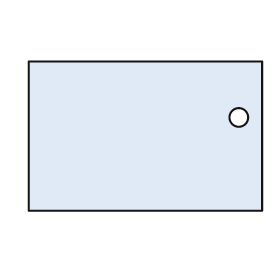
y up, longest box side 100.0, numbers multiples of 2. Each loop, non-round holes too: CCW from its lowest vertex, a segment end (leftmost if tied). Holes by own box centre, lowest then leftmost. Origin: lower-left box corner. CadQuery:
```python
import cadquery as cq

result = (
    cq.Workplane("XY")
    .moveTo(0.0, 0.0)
    .lineTo(100.0, 0.0)
    .lineTo(100.0, 64.0)
    .lineTo(0.0, 64.0)
    .close()
    .moveTo(90.0, 40.0)
    .circle(4.0)
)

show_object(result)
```